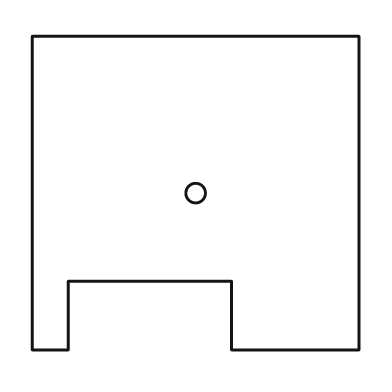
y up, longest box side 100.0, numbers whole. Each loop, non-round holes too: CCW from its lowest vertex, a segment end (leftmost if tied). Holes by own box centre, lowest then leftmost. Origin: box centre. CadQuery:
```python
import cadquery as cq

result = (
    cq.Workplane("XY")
    .moveTo(-50.0, -48.0)
    .lineTo(-39.0, -48.0)
    .lineTo(-39.0, -27.0)
    .lineTo(11.0, -27.0)
    .lineTo(11.0, -48.0)
    .lineTo(50.0, -48.0)
    .lineTo(50.0, 48.0)
    .lineTo(-50.0, 48.0)
    .close()
    .moveTo(0.0, 0.0)
    .circle(3.0)
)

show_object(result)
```